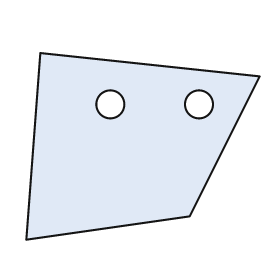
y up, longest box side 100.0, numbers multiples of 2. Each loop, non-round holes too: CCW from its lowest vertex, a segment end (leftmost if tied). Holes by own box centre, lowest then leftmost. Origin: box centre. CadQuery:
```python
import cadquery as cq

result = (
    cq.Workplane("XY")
    .moveTo(-50.0, -40.0)
    .lineTo(20.0, -30.0)
    .lineTo(50.0, 30.0)
    .lineTo(-44.0, 40.0)
    .close()
    .moveTo(-14.0, 18.0)
    .circle(6.0)
    .moveTo(24.0, 18.0)
    .circle(6.0)
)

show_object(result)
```